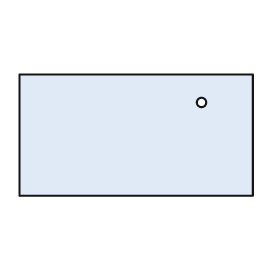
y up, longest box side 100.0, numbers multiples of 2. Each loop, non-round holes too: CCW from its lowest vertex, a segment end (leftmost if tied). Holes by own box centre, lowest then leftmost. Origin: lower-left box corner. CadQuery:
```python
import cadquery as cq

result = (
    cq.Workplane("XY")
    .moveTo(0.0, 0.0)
    .lineTo(100.0, 0.0)
    .lineTo(100.0, 52.0)
    .lineTo(0.0, 52.0)
    .close()
    .moveTo(78.0, 40.0)
    .circle(2.0)
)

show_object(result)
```